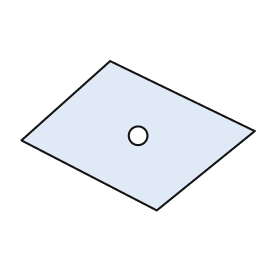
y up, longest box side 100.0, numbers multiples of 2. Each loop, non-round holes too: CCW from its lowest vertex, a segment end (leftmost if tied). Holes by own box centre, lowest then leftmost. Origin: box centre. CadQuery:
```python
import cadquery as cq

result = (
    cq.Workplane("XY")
    .moveTo(8.0, -32.0)
    .lineTo(50.0, 2.0)
    .lineTo(-12.0, 32.0)
    .lineTo(-50.0, -2.0)
    .close()
    .moveTo(0.0, 0.0)
    .circle(4.0)
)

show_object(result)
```